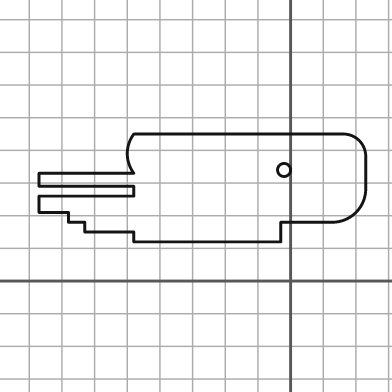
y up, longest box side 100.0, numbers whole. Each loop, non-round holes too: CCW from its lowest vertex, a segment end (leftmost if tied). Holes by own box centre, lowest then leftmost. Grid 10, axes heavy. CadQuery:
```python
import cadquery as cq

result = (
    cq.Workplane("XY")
    .moveTo(-48.0, 12.0)
    .lineTo(-3.0, 12.0)
    .lineTo(-3.0, 18.0)
    .lineTo(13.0, 18.0)
    .threePointArc((20.0, 21.0), (23.0, 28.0))
    .lineTo(23.0, 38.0)
    .threePointArc((21.0, 43.0), (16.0, 45.0))
    .lineTo(-48.0, 45.0)
    .threePointArc((-50.0, 39.0), (-48.0, 33.0))
    .lineTo(-77.0, 33.0)
    .lineTo(-77.0, 29.0)
    .lineTo(-48.0, 29.0)
    .lineTo(-48.0, 26.0)
    .lineTo(-77.0, 26.0)
    .lineTo(-77.0, 21.0)
    .lineTo(-68.0, 21.0)
    .lineTo(-68.0, 18.0)
    .lineTo(-63.0, 18.0)
    .lineTo(-63.0, 15.0)
    .lineTo(-48.0, 15.0)
    .close()
    .moveTo(-2.0, 34.0)
    .circle(2.0)
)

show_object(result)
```